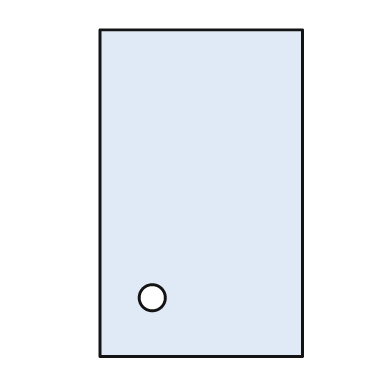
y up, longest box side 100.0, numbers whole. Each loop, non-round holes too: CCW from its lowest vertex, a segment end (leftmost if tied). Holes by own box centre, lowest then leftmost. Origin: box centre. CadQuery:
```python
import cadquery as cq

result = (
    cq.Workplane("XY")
    .moveTo(-31.0, -50.0)
    .lineTo(31.0, -50.0)
    .lineTo(31.0, 50.0)
    .lineTo(-31.0, 50.0)
    .close()
    .moveTo(-15.0, -32.0)
    .circle(4.0)
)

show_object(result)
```